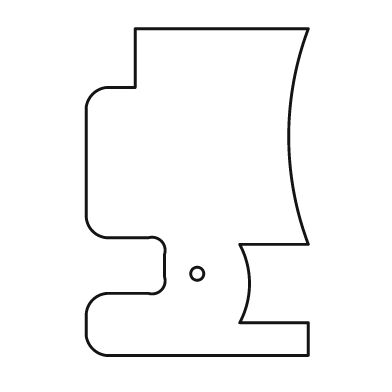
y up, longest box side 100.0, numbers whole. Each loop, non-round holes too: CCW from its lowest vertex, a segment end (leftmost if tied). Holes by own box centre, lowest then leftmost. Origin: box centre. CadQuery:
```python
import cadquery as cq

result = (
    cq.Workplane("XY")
    .moveTo(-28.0, -50.0)
    .lineTo(34.0, -50.0)
    .lineTo(34.0, -40.0)
    .lineTo(13.0, -40.0)
    .threePointArc((16.0, -28.0), (13.0, -16.0))
    .lineTo(34.0, -16.0)
    .threePointArc((28.0, 17.0), (34.0, 50.0))
    .lineTo(-19.0, 50.0)
    .lineTo(-19.0, 32.0)
    .lineTo(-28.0, 32.0)
    .threePointArc((-32.0, 30.0), (-34.0, 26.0))
    .lineTo(-34.0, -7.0)
    .threePointArc((-32.0, -12.0), (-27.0, -14.0))
    .lineTo(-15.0, -14.0)
    .threePointArc((-11.0, -15.0), (-10.0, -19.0))
    .lineTo(-10.0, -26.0)
    .threePointArc((-11.0, -30.0), (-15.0, -31.0))
    .lineTo(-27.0, -31.0)
    .threePointArc((-32.0, -33.0), (-34.0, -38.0))
    .lineTo(-34.0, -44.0)
    .threePointArc((-32.0, -48.0), (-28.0, -50.0))
    .close()
    .moveTo(0.0, -25.0)
    .circle(2.0)
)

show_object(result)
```